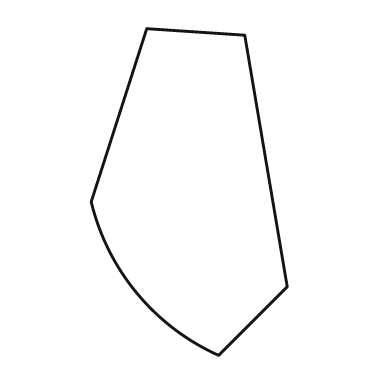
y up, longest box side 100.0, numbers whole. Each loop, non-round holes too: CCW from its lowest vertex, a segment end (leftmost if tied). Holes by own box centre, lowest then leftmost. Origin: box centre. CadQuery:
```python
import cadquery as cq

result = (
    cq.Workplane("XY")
    .moveTo(9.0, -50.0)
    .lineTo(30.0, -29.0)
    .lineTo(17.0, 48.0)
    .lineTo(-13.0, 50.0)
    .lineTo(-30.0, -3.0)
    .threePointArc((-16.0, -31.0), (9.0, -50.0))
    .close()
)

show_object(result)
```